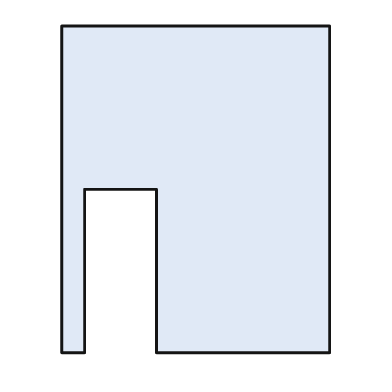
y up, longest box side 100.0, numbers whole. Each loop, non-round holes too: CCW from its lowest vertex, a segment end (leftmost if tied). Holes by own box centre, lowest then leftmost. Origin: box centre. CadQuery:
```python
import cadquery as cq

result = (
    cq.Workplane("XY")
    .moveTo(-41.0, -50.0)
    .lineTo(-34.0, -50.0)
    .lineTo(-34.0, 0.0)
    .lineTo(-12.0, 0.0)
    .lineTo(-12.0, -50.0)
    .lineTo(41.0, -50.0)
    .lineTo(41.0, 50.0)
    .lineTo(-41.0, 50.0)
    .close()
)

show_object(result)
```